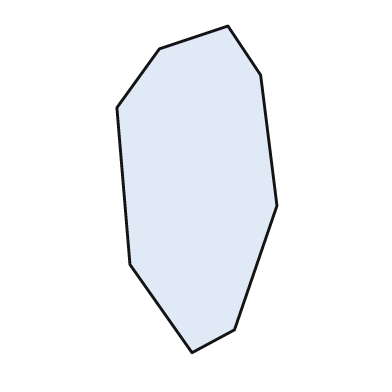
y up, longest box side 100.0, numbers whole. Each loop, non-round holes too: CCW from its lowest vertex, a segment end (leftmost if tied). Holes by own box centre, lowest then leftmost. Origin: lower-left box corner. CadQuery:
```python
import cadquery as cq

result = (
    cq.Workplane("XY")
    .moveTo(23.0, 0.0)
    .lineTo(36.0, 7.0)
    .lineTo(49.0, 45.0)
    .lineTo(44.0, 85.0)
    .lineTo(34.0, 100.0)
    .lineTo(13.0, 93.0)
    .lineTo(0.0, 75.0)
    .lineTo(4.0, 27.0)
    .close()
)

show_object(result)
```